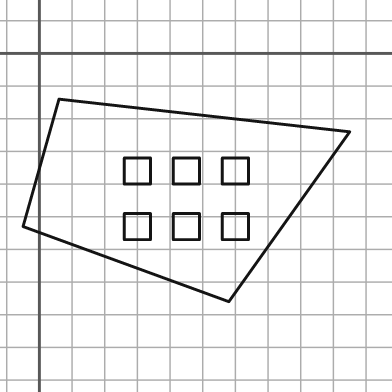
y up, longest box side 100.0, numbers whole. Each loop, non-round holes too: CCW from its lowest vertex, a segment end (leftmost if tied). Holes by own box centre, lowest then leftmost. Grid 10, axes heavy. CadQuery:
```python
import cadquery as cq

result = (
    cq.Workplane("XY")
    .moveTo(58.0, -76.0)
    .lineTo(95.0, -24.0)
    .lineTo(6.0, -14.0)
    .lineTo(-5.0, -53.0)
    .close()
    .moveTo(26.0, -57.0)
    .lineTo(34.0, -57.0)
    .lineTo(34.0, -49.0)
    .lineTo(26.0, -49.0)
    .close()
    .moveTo(41.0, -57.0)
    .lineTo(49.0, -57.0)
    .lineTo(49.0, -49.0)
    .lineTo(41.0, -49.0)
    .close()
    .moveTo(56.0, -57.0)
    .lineTo(64.0, -57.0)
    .lineTo(64.0, -49.0)
    .lineTo(56.0, -49.0)
    .close()
    .moveTo(26.0, -40.0)
    .lineTo(34.0, -40.0)
    .lineTo(34.0, -32.0)
    .lineTo(26.0, -32.0)
    .close()
    .moveTo(41.0, -40.0)
    .lineTo(49.0, -40.0)
    .lineTo(49.0, -32.0)
    .lineTo(41.0, -32.0)
    .close()
    .moveTo(56.0, -40.0)
    .lineTo(64.0, -40.0)
    .lineTo(64.0, -32.0)
    .lineTo(56.0, -32.0)
    .close()
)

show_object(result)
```